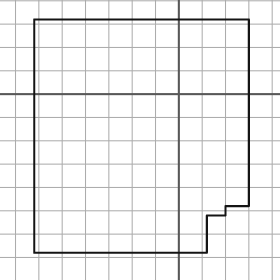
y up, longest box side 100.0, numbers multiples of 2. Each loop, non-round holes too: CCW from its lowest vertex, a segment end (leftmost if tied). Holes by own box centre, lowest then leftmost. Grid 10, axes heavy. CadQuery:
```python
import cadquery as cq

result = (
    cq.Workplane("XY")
    .moveTo(-62.0, -68.0)
    .lineTo(12.0, -68.0)
    .lineTo(12.0, -52.0)
    .lineTo(20.0, -52.0)
    .lineTo(20.0, -48.0)
    .lineTo(30.0, -48.0)
    .lineTo(30.0, 32.0)
    .lineTo(-62.0, 32.0)
    .close()
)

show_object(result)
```